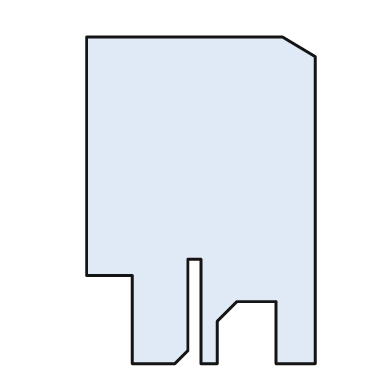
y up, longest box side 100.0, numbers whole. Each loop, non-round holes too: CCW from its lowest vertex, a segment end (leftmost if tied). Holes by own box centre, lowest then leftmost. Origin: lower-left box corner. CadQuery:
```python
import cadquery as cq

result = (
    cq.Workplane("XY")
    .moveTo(14.0, 0.0)
    .lineTo(27.0, 0.0)
    .lineTo(31.0, 4.0)
    .lineTo(31.0, 32.0)
    .lineTo(35.0, 32.0)
    .lineTo(35.0, 0.0)
    .lineTo(40.0, 0.0)
    .lineTo(40.0, 13.0)
    .lineTo(46.0, 19.0)
    .lineTo(58.0, 19.0)
    .lineTo(58.0, 0.0)
    .lineTo(70.0, 0.0)
    .lineTo(70.0, 94.0)
    .lineTo(60.0, 100.0)
    .lineTo(0.0, 100.0)
    .lineTo(0.0, 27.0)
    .lineTo(14.0, 27.0)
    .close()
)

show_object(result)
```